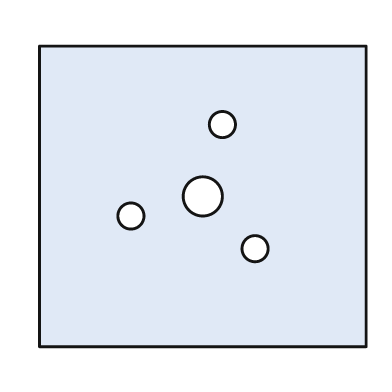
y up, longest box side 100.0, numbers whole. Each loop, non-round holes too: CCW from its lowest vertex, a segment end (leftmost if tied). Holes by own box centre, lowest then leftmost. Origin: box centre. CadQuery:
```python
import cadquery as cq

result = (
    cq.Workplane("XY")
    .moveTo(-50.0, -46.0)
    .lineTo(50.0, -46.0)
    .lineTo(50.0, 46.0)
    .lineTo(-50.0, 46.0)
    .close()
    .moveTo(16.0, -16.0)
    .circle(4.0)
    .moveTo(-22.0, -6.0)
    .circle(4.0)
    .moveTo(0.0, 0.0)
    .circle(6.0)
    .moveTo(6.0, 22.0)
    .circle(4.0)
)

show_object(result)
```